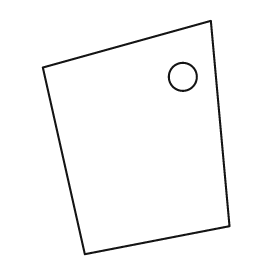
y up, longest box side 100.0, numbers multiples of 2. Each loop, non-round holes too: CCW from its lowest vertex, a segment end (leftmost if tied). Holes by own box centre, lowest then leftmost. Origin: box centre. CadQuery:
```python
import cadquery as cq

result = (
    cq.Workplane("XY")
    .moveTo(-22.0, -50.0)
    .lineTo(40.0, -38.0)
    .lineTo(32.0, 50.0)
    .lineTo(-40.0, 30.0)
    .close()
    .moveTo(20.0, 26.0)
    .circle(6.0)
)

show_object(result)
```